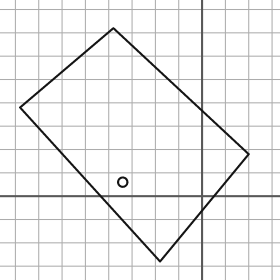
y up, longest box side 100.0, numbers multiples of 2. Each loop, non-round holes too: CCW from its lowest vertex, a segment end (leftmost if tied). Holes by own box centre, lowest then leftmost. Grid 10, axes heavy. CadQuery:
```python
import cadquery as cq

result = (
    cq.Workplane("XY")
    .moveTo(-18.0, -28.0)
    .lineTo(20.0, 18.0)
    .lineTo(-38.0, 72.0)
    .lineTo(-78.0, 38.0)
    .close()
    .moveTo(-34.0, 6.0)
    .circle(2.0)
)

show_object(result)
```